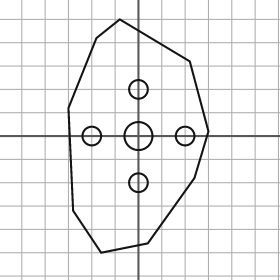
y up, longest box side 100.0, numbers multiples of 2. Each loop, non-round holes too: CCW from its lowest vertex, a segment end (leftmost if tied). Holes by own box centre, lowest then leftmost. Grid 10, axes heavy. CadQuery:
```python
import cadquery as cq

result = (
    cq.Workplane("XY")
    .moveTo(-16.0, -50.0)
    .lineTo(4.0, -46.0)
    .lineTo(24.0, -18.0)
    .lineTo(30.0, 2.0)
    .lineTo(22.0, 32.0)
    .lineTo(-8.0, 50.0)
    .lineTo(-18.0, 42.0)
    .lineTo(-30.0, 12.0)
    .lineTo(-28.0, -32.0)
    .close()
    .moveTo(0.0, -20.0)
    .circle(4.0)
    .moveTo(-20.0, 0.0)
    .circle(4.0)
    .moveTo(0.0, 0.0)
    .circle(6.0)
    .moveTo(20.0, 0.0)
    .circle(4.0)
    .moveTo(0.0, 20.0)
    .circle(4.0)
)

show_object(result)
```